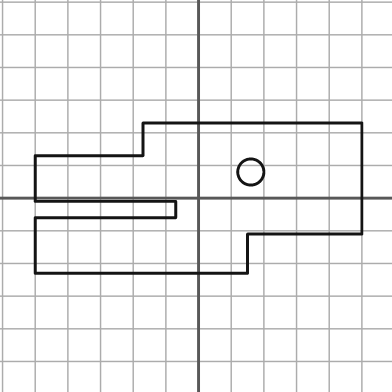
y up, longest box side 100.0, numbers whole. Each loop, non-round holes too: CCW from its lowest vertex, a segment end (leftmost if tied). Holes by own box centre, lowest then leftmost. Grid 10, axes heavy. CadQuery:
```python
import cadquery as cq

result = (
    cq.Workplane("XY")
    .moveTo(-50.0, -23.0)
    .lineTo(15.0, -23.0)
    .lineTo(15.0, -11.0)
    .lineTo(50.0, -11.0)
    .lineTo(50.0, 23.0)
    .lineTo(-17.0, 23.0)
    .lineTo(-17.0, 13.0)
    .lineTo(-50.0, 13.0)
    .lineTo(-50.0, -1.0)
    .lineTo(-7.0, -1.0)
    .lineTo(-7.0, -6.0)
    .lineTo(-50.0, -6.0)
    .close()
    .moveTo(16.0, 8.0)
    .circle(4.0)
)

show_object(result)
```